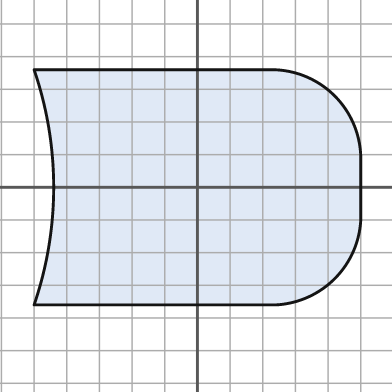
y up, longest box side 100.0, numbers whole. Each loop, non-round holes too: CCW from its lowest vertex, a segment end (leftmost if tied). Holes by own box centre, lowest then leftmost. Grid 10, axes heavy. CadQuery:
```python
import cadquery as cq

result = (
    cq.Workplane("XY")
    .moveTo(-50.0, -36.0)
    .lineTo(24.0, -36.0)
    .threePointArc((42.0, -28.0), (50.0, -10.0))
    .lineTo(50.0, 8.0)
    .threePointArc((42.0, 28.0), (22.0, 36.0))
    .lineTo(-50.0, 36.0)
    .threePointArc((-44.0, 0.0), (-50.0, -36.0))
    .close()
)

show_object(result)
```